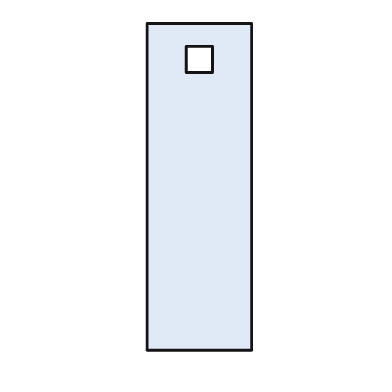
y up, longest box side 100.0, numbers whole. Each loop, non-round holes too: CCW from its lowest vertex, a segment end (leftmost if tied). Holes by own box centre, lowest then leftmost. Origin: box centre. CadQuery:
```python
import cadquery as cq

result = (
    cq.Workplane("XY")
    .moveTo(-16.0, -50.0)
    .lineTo(16.0, -50.0)
    .lineTo(16.0, 50.0)
    .lineTo(-16.0, 50.0)
    .close()
    .moveTo(-4.0, 35.0)
    .lineTo(4.0, 35.0)
    .lineTo(4.0, 43.0)
    .lineTo(-4.0, 43.0)
    .close()
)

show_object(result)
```